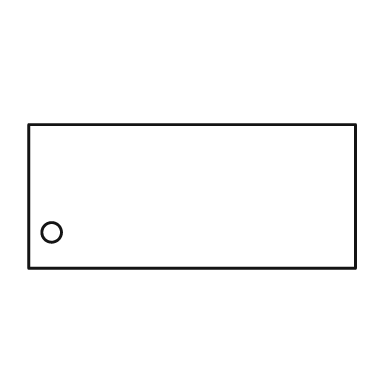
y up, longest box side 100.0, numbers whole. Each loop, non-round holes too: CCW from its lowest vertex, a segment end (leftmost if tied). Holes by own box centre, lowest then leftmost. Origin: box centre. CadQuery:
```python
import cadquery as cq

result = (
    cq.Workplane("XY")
    .moveTo(-50.0, -22.0)
    .lineTo(50.0, -22.0)
    .lineTo(50.0, 22.0)
    .lineTo(-50.0, 22.0)
    .close()
    .moveTo(-43.0, -11.0)
    .circle(3.0)
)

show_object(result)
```